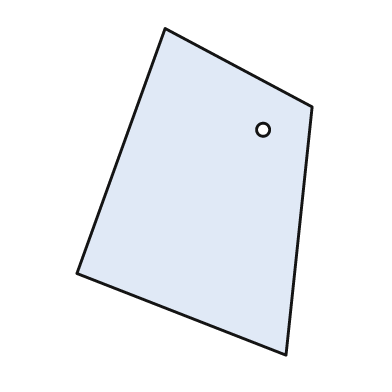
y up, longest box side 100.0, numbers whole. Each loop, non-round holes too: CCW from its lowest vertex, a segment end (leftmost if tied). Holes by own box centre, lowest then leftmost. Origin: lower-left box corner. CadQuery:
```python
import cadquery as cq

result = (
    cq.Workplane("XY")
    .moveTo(64.0, 0.0)
    .lineTo(72.0, 76.0)
    .lineTo(27.0, 100.0)
    .lineTo(0.0, 25.0)
    .close()
    .moveTo(57.0, 69.0)
    .circle(2.0)
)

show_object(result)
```